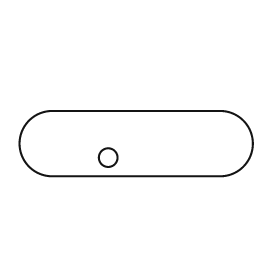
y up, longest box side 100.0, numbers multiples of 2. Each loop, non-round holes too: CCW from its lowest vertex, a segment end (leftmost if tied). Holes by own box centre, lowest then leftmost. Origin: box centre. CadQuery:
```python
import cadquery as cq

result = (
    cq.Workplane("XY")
    .moveTo(-36.0, -14.0)
    .lineTo(36.0, -14.0)
    .threePointArc((50.0, 0.0), (36.0, 14.0))
    .lineTo(-36.0, 14.0)
    .threePointArc((-50.0, 0.0), (-36.0, -14.0))
    .close()
    .moveTo(-12.0, -6.0)
    .circle(4.0)
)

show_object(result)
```